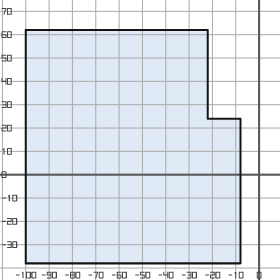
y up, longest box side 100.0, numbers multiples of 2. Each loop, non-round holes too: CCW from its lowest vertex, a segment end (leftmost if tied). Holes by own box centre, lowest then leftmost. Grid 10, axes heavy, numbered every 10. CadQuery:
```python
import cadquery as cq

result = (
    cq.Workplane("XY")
    .moveTo(-100.0, -38.0)
    .lineTo(-8.0, -38.0)
    .lineTo(-8.0, 24.0)
    .lineTo(-22.0, 24.0)
    .lineTo(-22.0, 62.0)
    .lineTo(-100.0, 62.0)
    .close()
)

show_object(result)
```